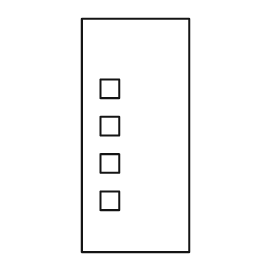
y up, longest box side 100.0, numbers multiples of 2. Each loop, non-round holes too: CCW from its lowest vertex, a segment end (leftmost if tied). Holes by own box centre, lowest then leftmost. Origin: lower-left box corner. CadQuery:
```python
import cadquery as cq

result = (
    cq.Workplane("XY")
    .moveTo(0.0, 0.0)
    .lineTo(46.0, 0.0)
    .lineTo(46.0, 100.0)
    .lineTo(0.0, 100.0)
    .close()
    .moveTo(8.0, 18.0)
    .lineTo(16.0, 18.0)
    .lineTo(16.0, 26.0)
    .lineTo(8.0, 26.0)
    .close()
    .moveTo(8.0, 34.0)
    .lineTo(16.0, 34.0)
    .lineTo(16.0, 42.0)
    .lineTo(8.0, 42.0)
    .close()
    .moveTo(8.0, 50.0)
    .lineTo(16.0, 50.0)
    .lineTo(16.0, 58.0)
    .lineTo(8.0, 58.0)
    .close()
    .moveTo(8.0, 66.0)
    .lineTo(16.0, 66.0)
    .lineTo(16.0, 74.0)
    .lineTo(8.0, 74.0)
    .close()
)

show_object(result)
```